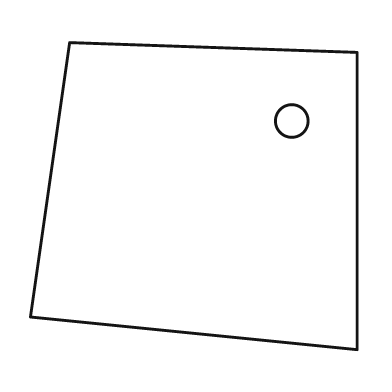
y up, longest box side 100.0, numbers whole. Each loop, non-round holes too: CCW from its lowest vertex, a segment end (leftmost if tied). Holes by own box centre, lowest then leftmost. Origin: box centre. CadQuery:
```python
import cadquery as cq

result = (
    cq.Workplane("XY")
    .moveTo(50.0, -47.0)
    .lineTo(50.0, 44.0)
    .lineTo(-38.0, 47.0)
    .lineTo(-50.0, -37.0)
    .close()
    .moveTo(30.0, 23.0)
    .circle(5.0)
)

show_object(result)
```